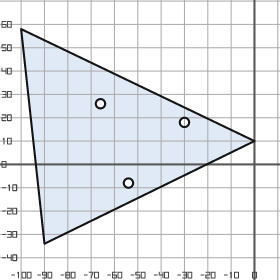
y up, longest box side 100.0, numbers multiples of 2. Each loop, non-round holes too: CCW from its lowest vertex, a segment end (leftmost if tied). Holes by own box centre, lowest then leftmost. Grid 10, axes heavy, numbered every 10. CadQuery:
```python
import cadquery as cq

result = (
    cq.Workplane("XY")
    .moveTo(-90.0, -34.0)
    .lineTo(0.0, 10.0)
    .lineTo(-100.0, 58.0)
    .close()
    .moveTo(-54.0, -8.0)
    .circle(2.0)
    .moveTo(-30.0, 18.0)
    .circle(2.0)
    .moveTo(-66.0, 26.0)
    .circle(2.0)
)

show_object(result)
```